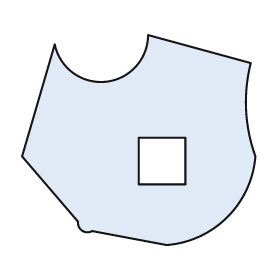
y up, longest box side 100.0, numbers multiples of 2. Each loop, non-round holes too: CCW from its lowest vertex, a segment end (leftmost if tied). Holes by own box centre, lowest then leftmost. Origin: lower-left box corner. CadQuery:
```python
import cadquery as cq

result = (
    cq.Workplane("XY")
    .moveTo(62.0, 0.0)
    .threePointArc((88.0, 12.0), (100.0, 38.0))
    .threePointArc((96.0, 58.0), (98.0, 78.0))
    .lineTo(54.0, 90.0)
    .threePointArc((36.0, 70.0), (14.0, 86.0))
    .lineTo(0.0, 38.0)
    .lineTo(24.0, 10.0)
    .threePointArc((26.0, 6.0), (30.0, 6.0))
    .close()
    .moveTo(50.0, 26.0)
    .lineTo(70.0, 26.0)
    .lineTo(70.0, 46.0)
    .lineTo(50.0, 46.0)
    .close()
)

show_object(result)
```